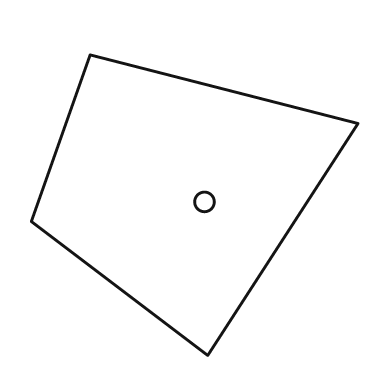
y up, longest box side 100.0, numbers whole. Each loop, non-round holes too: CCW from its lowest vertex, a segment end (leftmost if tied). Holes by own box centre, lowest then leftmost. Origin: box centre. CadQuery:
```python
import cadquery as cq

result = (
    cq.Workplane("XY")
    .moveTo(4.0, -46.0)
    .lineTo(50.0, 25.0)
    .lineTo(-32.0, 46.0)
    .lineTo(-50.0, -5.0)
    .close()
    .moveTo(3.0, 1.0)
    .circle(3.0)
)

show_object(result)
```